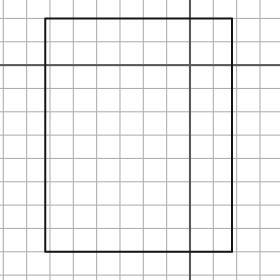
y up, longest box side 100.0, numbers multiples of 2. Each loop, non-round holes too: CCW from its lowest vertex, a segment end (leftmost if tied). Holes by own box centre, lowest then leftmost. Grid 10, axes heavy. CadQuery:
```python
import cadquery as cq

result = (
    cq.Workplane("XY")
    .moveTo(-62.0, -80.0)
    .lineTo(18.0, -80.0)
    .lineTo(18.0, 20.0)
    .lineTo(-62.0, 20.0)
    .close()
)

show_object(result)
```